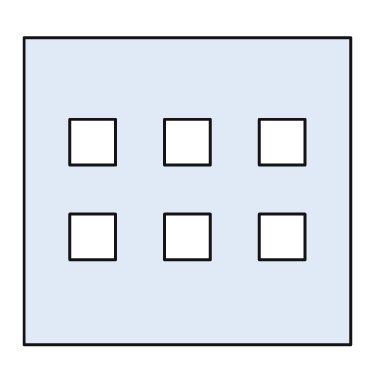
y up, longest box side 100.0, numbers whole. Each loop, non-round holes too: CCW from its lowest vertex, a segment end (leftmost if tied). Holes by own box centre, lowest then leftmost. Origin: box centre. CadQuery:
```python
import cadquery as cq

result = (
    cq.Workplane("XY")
    .moveTo(-50.0, -47.0)
    .lineTo(50.0, -47.0)
    .lineTo(50.0, 47.0)
    .lineTo(-50.0, 47.0)
    .close()
    .moveTo(-36.0, -21.0)
    .lineTo(-22.0, -21.0)
    .lineTo(-22.0, -7.0)
    .lineTo(-36.0, -7.0)
    .close()
    .moveTo(-7.0, -21.0)
    .lineTo(7.0, -21.0)
    .lineTo(7.0, -7.0)
    .lineTo(-7.0, -7.0)
    .close()
    .moveTo(22.0, -21.0)
    .lineTo(36.0, -21.0)
    .lineTo(36.0, -7.0)
    .lineTo(22.0, -7.0)
    .close()
    .moveTo(-36.0, 8.0)
    .lineTo(-22.0, 8.0)
    .lineTo(-22.0, 22.0)
    .lineTo(-36.0, 22.0)
    .close()
    .moveTo(-7.0, 8.0)
    .lineTo(7.0, 8.0)
    .lineTo(7.0, 22.0)
    .lineTo(-7.0, 22.0)
    .close()
    .moveTo(22.0, 8.0)
    .lineTo(36.0, 8.0)
    .lineTo(36.0, 22.0)
    .lineTo(22.0, 22.0)
    .close()
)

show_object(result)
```